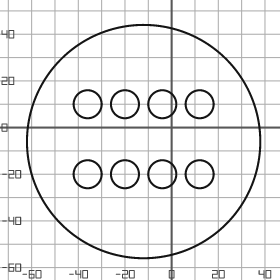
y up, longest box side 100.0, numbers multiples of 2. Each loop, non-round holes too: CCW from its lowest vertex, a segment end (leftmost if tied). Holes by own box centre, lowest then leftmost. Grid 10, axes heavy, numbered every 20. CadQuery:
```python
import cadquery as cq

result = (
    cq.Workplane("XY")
    .moveTo(-12.0, -6.0)
    .circle(50.0)
    .moveTo(-36.0, -20.0)
    .circle(6.0)
    .moveTo(-20.0, -20.0)
    .circle(6.0)
    .moveTo(-4.0, -20.0)
    .circle(6.0)
    .moveTo(12.0, -20.0)
    .circle(6.0)
    .moveTo(-36.0, 10.0)
    .circle(6.0)
    .moveTo(-20.0, 10.0)
    .circle(6.0)
    .moveTo(-4.0, 10.0)
    .circle(6.0)
    .moveTo(12.0, 10.0)
    .circle(6.0)
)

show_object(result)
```